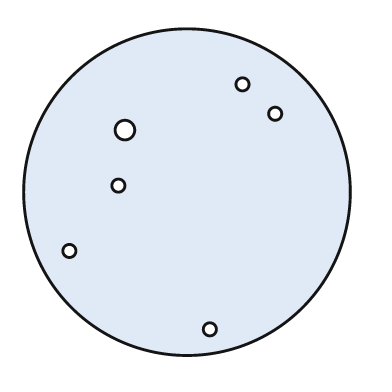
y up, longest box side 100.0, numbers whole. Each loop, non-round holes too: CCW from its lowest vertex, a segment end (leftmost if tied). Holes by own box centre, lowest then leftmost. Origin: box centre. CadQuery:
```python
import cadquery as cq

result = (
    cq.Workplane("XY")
    .moveTo(0.0, 0.0)
    .circle(50.0)
    .moveTo(7.0, -42.0)
    .circle(2.0)
    .moveTo(-36.0, -18.0)
    .circle(2.0)
    .moveTo(-21.0, 2.0)
    .circle(2.0)
    .moveTo(-19.0, 19.0)
    .circle(3.0)
    .moveTo(27.0, 24.0)
    .circle(2.0)
    .moveTo(17.0, 33.0)
    .circle(2.0)
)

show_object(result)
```